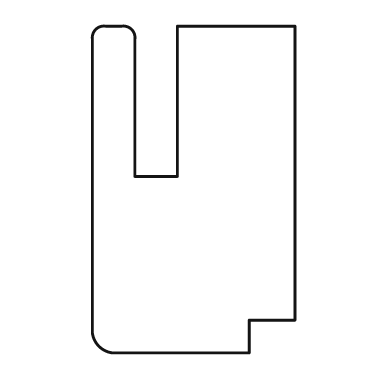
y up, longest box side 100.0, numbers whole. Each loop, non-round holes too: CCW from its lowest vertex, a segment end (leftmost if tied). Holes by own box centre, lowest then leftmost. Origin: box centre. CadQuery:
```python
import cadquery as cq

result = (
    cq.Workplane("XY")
    .moveTo(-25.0, -50.0)
    .lineTo(17.0, -50.0)
    .lineTo(17.0, -40.0)
    .lineTo(31.0, -40.0)
    .lineTo(31.0, 50.0)
    .lineTo(-5.0, 50.0)
    .lineTo(-5.0, 4.0)
    .lineTo(-18.0, 4.0)
    .lineTo(-18.0, 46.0)
    .threePointArc((-19.0, 49.0), (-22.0, 50.0))
    .lineTo(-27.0, 50.0)
    .threePointArc((-30.0, 49.0), (-31.0, 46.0))
    .lineTo(-31.0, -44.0)
    .threePointArc((-29.0, -48.0), (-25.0, -50.0))
    .close()
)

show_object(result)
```